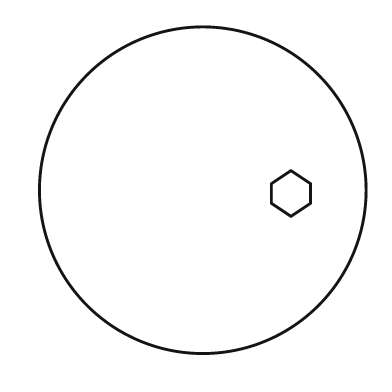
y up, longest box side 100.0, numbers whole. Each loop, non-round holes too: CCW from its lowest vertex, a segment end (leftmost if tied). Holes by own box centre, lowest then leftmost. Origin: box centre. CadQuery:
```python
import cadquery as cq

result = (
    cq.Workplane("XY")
    .moveTo(0.0, 0.0)
    .circle(50.0)
    .moveTo(27.0, -8.0)
    .lineTo(33.0, -4.0)
    .lineTo(33.0, 2.0)
    .lineTo(27.0, 6.0)
    .lineTo(21.0, 2.0)
    .lineTo(21.0, -4.0)
    .close()
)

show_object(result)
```